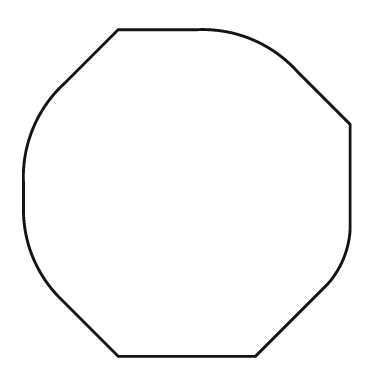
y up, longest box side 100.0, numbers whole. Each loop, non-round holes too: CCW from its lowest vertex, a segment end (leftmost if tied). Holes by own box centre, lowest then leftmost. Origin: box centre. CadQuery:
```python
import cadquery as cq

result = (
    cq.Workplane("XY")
    .moveTo(-21.0, -50.0)
    .lineTo(21.0, -50.0)
    .lineTo(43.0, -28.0)
    .threePointArc((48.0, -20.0), (50.0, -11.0))
    .lineTo(50.0, 21.0)
    .lineTo(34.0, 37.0)
    .threePointArc((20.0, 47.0), (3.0, 50.0))
    .lineTo(-21.0, 50.0)
    .lineTo(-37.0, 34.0)
    .threePointArc((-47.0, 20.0), (-50.0, 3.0))
    .lineTo(-50.0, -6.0)
    .threePointArc((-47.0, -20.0), (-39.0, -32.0))
    .close()
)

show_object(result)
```